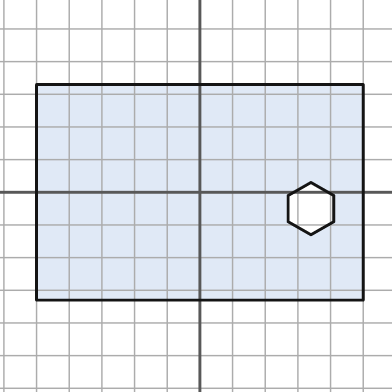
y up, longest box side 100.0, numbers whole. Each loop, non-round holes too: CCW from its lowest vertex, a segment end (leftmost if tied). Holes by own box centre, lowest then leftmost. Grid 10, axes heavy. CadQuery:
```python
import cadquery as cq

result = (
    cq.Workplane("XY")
    .moveTo(-50.0, -33.0)
    .lineTo(50.0, -33.0)
    .lineTo(50.0, 33.0)
    .lineTo(-50.0, 33.0)
    .close()
    .moveTo(34.0, -13.0)
    .lineTo(41.0, -9.0)
    .lineTo(41.0, -1.0)
    .lineTo(34.0, 3.0)
    .lineTo(27.0, -1.0)
    .lineTo(27.0, -9.0)
    .close()
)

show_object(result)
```